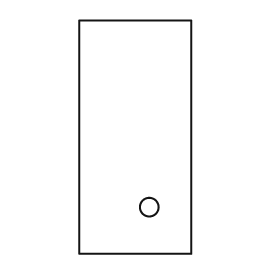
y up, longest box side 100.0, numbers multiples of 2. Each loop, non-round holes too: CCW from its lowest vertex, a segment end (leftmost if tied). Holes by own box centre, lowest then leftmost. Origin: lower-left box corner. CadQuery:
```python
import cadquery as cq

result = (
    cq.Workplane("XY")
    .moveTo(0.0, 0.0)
    .lineTo(48.0, 0.0)
    .lineTo(48.0, 100.0)
    .lineTo(0.0, 100.0)
    .close()
    .moveTo(30.0, 20.0)
    .circle(4.0)
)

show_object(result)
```